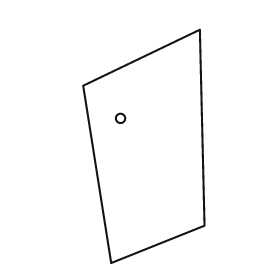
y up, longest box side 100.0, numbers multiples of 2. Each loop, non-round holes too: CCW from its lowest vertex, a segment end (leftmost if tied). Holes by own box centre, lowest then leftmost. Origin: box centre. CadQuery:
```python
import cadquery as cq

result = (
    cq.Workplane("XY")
    .moveTo(-14.0, -50.0)
    .lineTo(26.0, -34.0)
    .lineTo(24.0, 50.0)
    .lineTo(-26.0, 26.0)
    .close()
    .moveTo(-10.0, 12.0)
    .circle(2.0)
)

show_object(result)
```